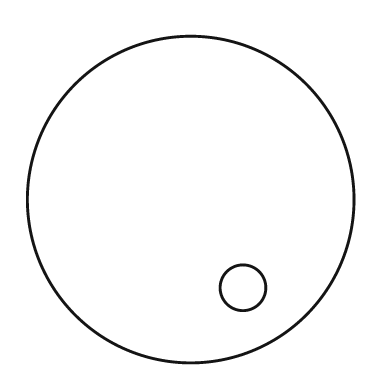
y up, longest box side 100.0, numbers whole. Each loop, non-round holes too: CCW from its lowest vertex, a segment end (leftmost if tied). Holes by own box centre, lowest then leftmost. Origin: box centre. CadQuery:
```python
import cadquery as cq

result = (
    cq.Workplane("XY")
    .moveTo(0.0, 0.0)
    .circle(50.0)
    .moveTo(16.0, -27.0)
    .circle(7.0)
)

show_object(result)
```